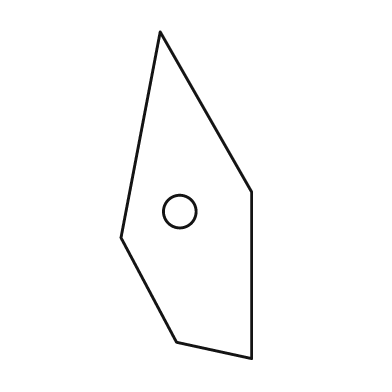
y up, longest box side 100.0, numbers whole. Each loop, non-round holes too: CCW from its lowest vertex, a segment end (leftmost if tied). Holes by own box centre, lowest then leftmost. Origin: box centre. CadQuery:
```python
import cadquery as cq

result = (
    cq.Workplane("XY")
    .moveTo(20.0, -50.0)
    .lineTo(20.0, 1.0)
    .lineTo(-8.0, 50.0)
    .lineTo(-20.0, -13.0)
    .lineTo(-3.0, -45.0)
    .close()
    .moveTo(-2.0, -5.0)
    .circle(5.0)
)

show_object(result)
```